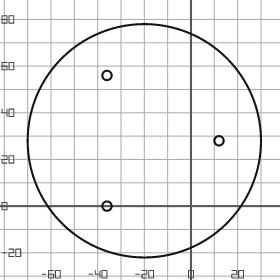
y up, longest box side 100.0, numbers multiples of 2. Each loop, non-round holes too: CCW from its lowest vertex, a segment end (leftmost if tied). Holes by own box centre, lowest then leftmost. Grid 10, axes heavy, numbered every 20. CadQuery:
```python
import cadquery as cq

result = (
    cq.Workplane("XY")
    .moveTo(-20.0, 28.0)
    .circle(50.0)
    .moveTo(-36.0, 0.0)
    .circle(2.0)
    .moveTo(12.0, 28.0)
    .circle(2.0)
    .moveTo(-36.0, 56.0)
    .circle(2.0)
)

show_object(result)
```